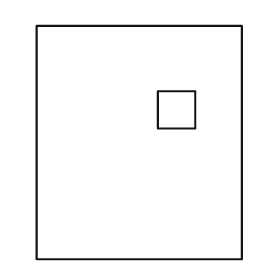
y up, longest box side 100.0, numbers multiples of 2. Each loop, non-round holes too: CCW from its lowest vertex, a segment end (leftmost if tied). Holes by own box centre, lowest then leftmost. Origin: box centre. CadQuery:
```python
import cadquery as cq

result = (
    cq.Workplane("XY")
    .moveTo(-44.0, -50.0)
    .lineTo(44.0, -50.0)
    .lineTo(44.0, 50.0)
    .lineTo(-44.0, 50.0)
    .close()
    .moveTo(8.0, 6.0)
    .lineTo(24.0, 6.0)
    .lineTo(24.0, 22.0)
    .lineTo(8.0, 22.0)
    .close()
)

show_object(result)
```